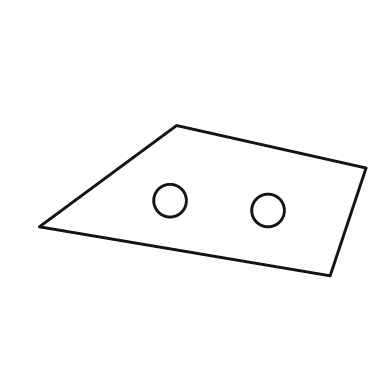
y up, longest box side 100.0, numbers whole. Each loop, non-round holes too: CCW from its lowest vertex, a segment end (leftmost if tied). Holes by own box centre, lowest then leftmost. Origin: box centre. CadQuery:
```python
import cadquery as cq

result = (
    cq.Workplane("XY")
    .moveTo(39.0, -23.0)
    .lineTo(50.0, 10.0)
    .lineTo(-8.0, 23.0)
    .lineTo(-50.0, -8.0)
    .close()
    .moveTo(20.0, -3.0)
    .circle(5.0)
    .moveTo(-10.0, 0.0)
    .circle(5.0)
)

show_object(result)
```